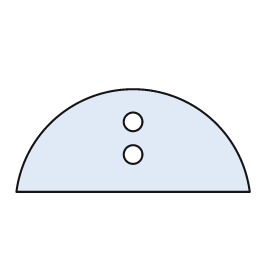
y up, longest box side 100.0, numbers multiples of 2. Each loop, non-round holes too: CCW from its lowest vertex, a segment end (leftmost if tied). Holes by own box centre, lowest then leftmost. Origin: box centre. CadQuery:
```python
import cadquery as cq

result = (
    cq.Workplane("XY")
    .moveTo(-50.0, -22.0)
    .lineTo(50.0, -22.0)
    .threePointArc((0.0, 22.0), (-50.0, -22.0))
    .close()
    .moveTo(0.0, -6.0)
    .circle(4.0)
    .moveTo(0.0, 8.0)
    .circle(4.0)
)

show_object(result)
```